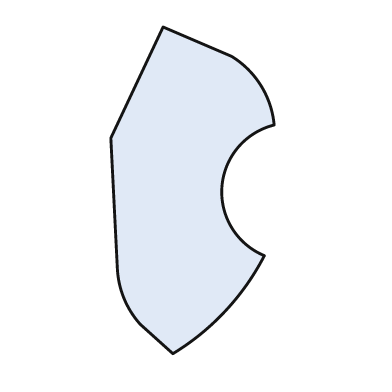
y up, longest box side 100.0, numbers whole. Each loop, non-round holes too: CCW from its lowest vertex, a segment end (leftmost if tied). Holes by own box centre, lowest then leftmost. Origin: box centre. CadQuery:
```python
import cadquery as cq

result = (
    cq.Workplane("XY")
    .moveTo(-6.0, -50.0)
    .threePointArc((10.0, -37.0), (22.0, -20.0))
    .threePointArc((9.0, 1.0), (25.0, 20.0))
    .threePointArc((21.0, 32.0), (12.0, 41.0))
    .lineTo(-9.0, 50.0)
    .lineTo(-25.0, 16.0)
    .lineTo(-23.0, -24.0)
    .threePointArc((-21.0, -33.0), (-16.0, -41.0))
    .close()
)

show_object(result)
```